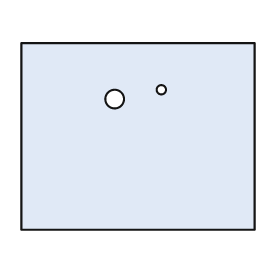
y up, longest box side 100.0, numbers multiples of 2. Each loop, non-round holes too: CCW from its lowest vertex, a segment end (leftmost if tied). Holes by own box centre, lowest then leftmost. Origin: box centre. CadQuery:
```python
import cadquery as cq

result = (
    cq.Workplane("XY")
    .moveTo(-50.0, -40.0)
    .lineTo(50.0, -40.0)
    .lineTo(50.0, 40.0)
    .lineTo(-50.0, 40.0)
    .close()
    .moveTo(-10.0, 16.0)
    .circle(4.0)
    .moveTo(10.0, 20.0)
    .circle(2.0)
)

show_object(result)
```